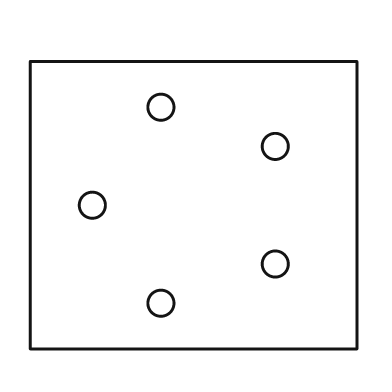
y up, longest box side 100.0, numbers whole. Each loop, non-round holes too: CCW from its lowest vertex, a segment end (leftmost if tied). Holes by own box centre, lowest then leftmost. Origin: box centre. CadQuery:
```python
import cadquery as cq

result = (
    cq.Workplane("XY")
    .moveTo(-50.0, -44.0)
    .lineTo(50.0, -44.0)
    .lineTo(50.0, 44.0)
    .lineTo(-50.0, 44.0)
    .close()
    .moveTo(-10.0, -30.0)
    .circle(4.0)
    .moveTo(25.0, -18.0)
    .circle(4.0)
    .moveTo(-31.0, 0.0)
    .circle(4.0)
    .moveTo(25.0, 18.0)
    .circle(4.0)
    .moveTo(-10.0, 30.0)
    .circle(4.0)
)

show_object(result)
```